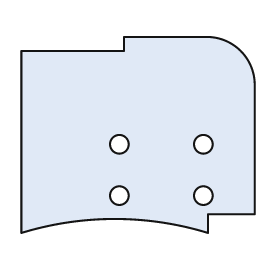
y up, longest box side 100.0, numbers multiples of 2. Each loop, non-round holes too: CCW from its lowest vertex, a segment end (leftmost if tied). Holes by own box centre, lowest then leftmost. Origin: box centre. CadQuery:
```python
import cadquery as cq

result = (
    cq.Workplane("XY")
    .moveTo(-50.0, -42.0)
    .threePointArc((-10.0, -36.0), (30.0, -42.0))
    .lineTo(30.0, -34.0)
    .lineTo(50.0, -34.0)
    .lineTo(50.0, 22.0)
    .threePointArc((44.0, 36.0), (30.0, 42.0))
    .lineTo(-6.0, 42.0)
    .lineTo(-6.0, 36.0)
    .lineTo(-50.0, 36.0)
    .close()
    .moveTo(-8.0, -26.0)
    .circle(4.0)
    .moveTo(28.0, -26.0)
    .circle(4.0)
    .moveTo(-8.0, -4.0)
    .circle(4.0)
    .moveTo(28.0, -4.0)
    .circle(4.0)
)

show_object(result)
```